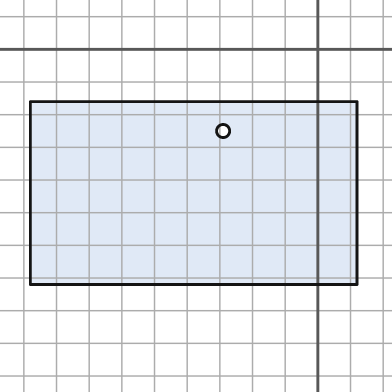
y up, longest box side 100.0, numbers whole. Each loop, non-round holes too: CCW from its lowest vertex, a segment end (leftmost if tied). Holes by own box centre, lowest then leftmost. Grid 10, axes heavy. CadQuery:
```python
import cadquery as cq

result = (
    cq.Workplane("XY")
    .moveTo(-88.0, -72.0)
    .lineTo(12.0, -72.0)
    .lineTo(12.0, -16.0)
    .lineTo(-88.0, -16.0)
    .close()
    .moveTo(-29.0, -25.0)
    .circle(2.0)
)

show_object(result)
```